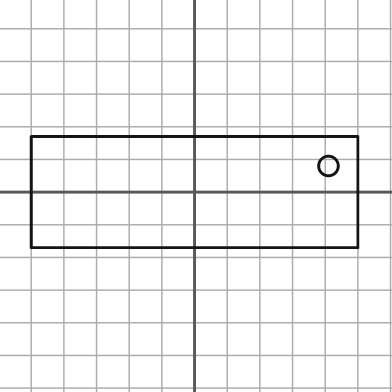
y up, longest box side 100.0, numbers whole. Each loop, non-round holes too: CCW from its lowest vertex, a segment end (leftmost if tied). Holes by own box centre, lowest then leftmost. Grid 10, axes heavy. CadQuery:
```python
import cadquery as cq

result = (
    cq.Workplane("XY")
    .moveTo(-50.0, -17.0)
    .lineTo(50.0, -17.0)
    .lineTo(50.0, 17.0)
    .lineTo(-50.0, 17.0)
    .close()
    .moveTo(41.0, 8.0)
    .circle(3.0)
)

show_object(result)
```